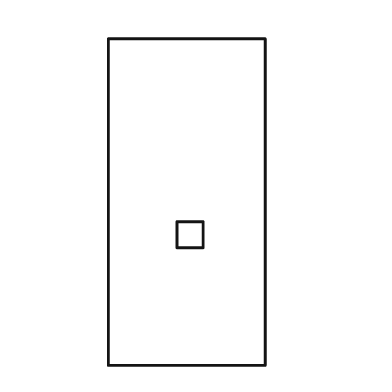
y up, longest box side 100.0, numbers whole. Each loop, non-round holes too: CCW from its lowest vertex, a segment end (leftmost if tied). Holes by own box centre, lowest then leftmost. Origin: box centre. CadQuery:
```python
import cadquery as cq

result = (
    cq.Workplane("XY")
    .moveTo(-24.0, -50.0)
    .lineTo(24.0, -50.0)
    .lineTo(24.0, 50.0)
    .lineTo(-24.0, 50.0)
    .close()
    .moveTo(-3.0, -14.0)
    .lineTo(5.0, -14.0)
    .lineTo(5.0, -6.0)
    .lineTo(-3.0, -6.0)
    .close()
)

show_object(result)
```